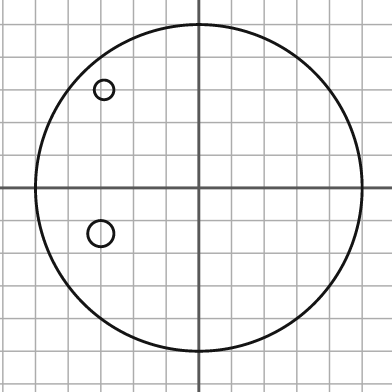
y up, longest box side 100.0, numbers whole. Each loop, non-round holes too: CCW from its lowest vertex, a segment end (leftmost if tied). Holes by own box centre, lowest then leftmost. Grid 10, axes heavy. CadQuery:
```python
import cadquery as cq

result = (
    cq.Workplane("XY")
    .moveTo(0.0, 0.0)
    .circle(50.0)
    .moveTo(-30.0, -14.0)
    .circle(4.0)
    .moveTo(-29.0, 30.0)
    .circle(3.0)
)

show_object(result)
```